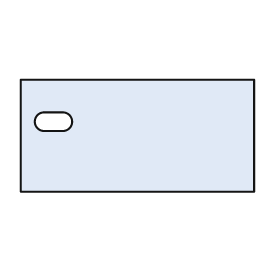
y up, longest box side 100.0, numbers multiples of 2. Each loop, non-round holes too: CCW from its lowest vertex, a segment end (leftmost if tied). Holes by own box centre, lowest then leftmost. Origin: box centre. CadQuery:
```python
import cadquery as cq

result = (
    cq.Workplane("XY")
    .moveTo(-50.0, -24.0)
    .lineTo(50.0, -24.0)
    .lineTo(50.0, 24.0)
    .lineTo(-50.0, 24.0)
    .close()
    .moveTo(-40.0, 2.0)
    .lineTo(-32.0, 2.0)
    .threePointArc((-28.0, 6.0), (-32.0, 10.0))
    .lineTo(-40.0, 10.0)
    .threePointArc((-44.0, 6.0), (-40.0, 2.0))
    .close()
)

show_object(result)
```